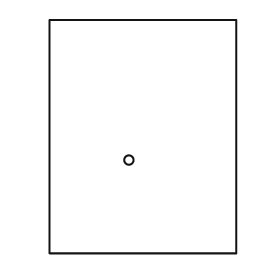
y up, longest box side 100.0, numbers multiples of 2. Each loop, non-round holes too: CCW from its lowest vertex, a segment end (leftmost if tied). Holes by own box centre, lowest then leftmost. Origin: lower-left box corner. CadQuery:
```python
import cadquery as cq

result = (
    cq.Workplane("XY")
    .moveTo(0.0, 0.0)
    .lineTo(80.0, 0.0)
    .lineTo(80.0, 100.0)
    .lineTo(0.0, 100.0)
    .close()
    .moveTo(34.0, 40.0)
    .circle(2.0)
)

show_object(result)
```